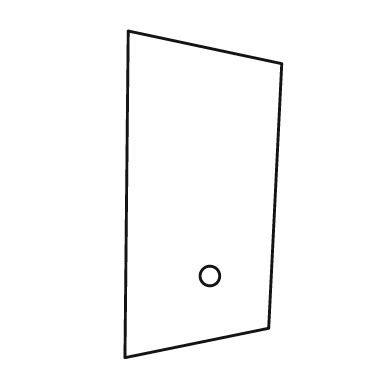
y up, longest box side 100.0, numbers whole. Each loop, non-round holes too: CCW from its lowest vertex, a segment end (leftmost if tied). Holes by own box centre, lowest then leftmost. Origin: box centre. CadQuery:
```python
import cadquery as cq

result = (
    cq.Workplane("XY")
    .moveTo(-24.0, -50.0)
    .lineTo(20.0, -41.0)
    .lineTo(24.0, 40.0)
    .lineTo(-23.0, 50.0)
    .close()
    .moveTo(2.0, -25.0)
    .circle(3.0)
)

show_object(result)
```